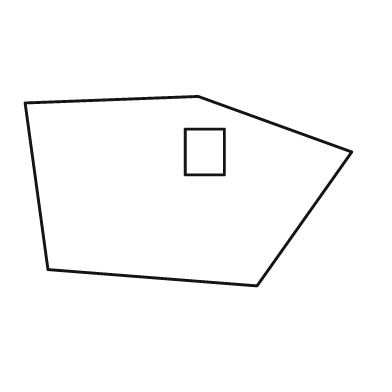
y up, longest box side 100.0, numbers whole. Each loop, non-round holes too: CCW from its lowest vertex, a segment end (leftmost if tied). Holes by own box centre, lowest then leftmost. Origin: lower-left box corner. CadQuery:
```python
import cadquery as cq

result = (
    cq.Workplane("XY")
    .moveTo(71.0, 0.0)
    .lineTo(100.0, 41.0)
    .lineTo(53.0, 58.0)
    .lineTo(0.0, 56.0)
    .lineTo(7.0, 5.0)
    .close()
    .moveTo(49.0, 34.0)
    .lineTo(61.0, 34.0)
    .lineTo(61.0, 48.0)
    .lineTo(49.0, 48.0)
    .close()
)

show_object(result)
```